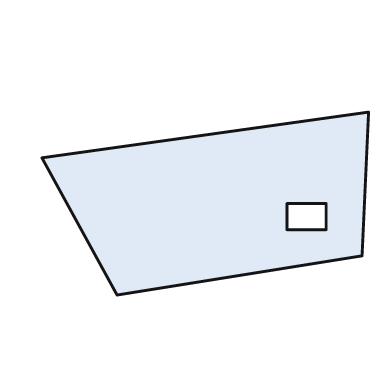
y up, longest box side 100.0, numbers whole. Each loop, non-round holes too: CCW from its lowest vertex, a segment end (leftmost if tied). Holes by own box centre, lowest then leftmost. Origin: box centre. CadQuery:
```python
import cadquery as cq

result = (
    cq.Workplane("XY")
    .moveTo(-27.0, -28.0)
    .lineTo(48.0, -16.0)
    .lineTo(50.0, 28.0)
    .lineTo(-50.0, 14.0)
    .close()
    .moveTo(25.0, -8.0)
    .lineTo(37.0, -8.0)
    .lineTo(37.0, 0.0)
    .lineTo(25.0, 0.0)
    .close()
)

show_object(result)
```